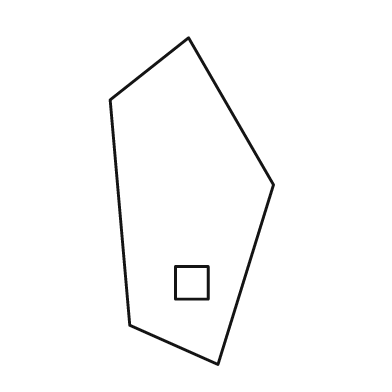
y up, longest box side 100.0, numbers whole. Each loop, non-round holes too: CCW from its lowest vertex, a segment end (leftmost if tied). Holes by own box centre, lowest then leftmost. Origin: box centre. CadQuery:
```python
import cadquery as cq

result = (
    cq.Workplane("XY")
    .moveTo(8.0, -50.0)
    .lineTo(25.0, 5.0)
    .lineTo(-1.0, 50.0)
    .lineTo(-25.0, 31.0)
    .lineTo(-19.0, -38.0)
    .close()
    .moveTo(-5.0, -30.0)
    .lineTo(5.0, -30.0)
    .lineTo(5.0, -20.0)
    .lineTo(-5.0, -20.0)
    .close()
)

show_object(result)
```